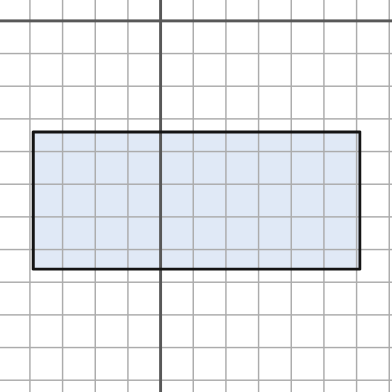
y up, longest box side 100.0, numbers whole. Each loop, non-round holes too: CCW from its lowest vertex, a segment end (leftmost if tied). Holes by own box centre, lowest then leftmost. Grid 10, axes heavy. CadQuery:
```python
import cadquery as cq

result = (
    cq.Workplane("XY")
    .moveTo(-39.0, -76.0)
    .lineTo(61.0, -76.0)
    .lineTo(61.0, -34.0)
    .lineTo(-39.0, -34.0)
    .close()
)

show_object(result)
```